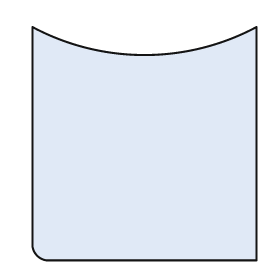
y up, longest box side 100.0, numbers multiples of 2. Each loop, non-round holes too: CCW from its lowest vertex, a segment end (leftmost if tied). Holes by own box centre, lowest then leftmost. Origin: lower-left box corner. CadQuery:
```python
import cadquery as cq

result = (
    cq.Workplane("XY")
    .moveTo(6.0, 0.0)
    .lineTo(96.0, 0.0)
    .lineTo(96.0, 100.0)
    .threePointArc((48.0, 88.0), (0.0, 100.0))
    .lineTo(0.0, 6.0)
    .threePointArc((2.0, 2.0), (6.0, 0.0))
    .close()
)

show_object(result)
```